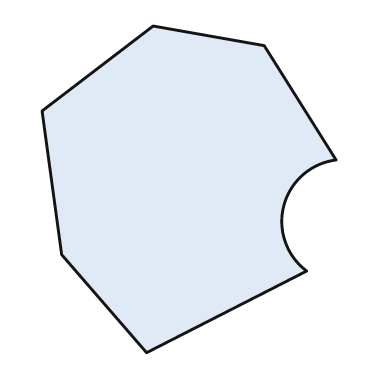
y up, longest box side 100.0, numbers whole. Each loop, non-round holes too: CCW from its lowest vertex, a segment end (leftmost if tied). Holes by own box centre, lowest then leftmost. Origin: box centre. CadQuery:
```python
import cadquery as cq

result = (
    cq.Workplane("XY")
    .moveTo(-13.0, -50.0)
    .lineTo(36.0, -25.0)
    .threePointArc((29.0, -5.0), (45.0, 9.0))
    .lineTo(23.0, 44.0)
    .lineTo(-11.0, 50.0)
    .lineTo(-45.0, 24.0)
    .lineTo(-39.0, -20.0)
    .close()
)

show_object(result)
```